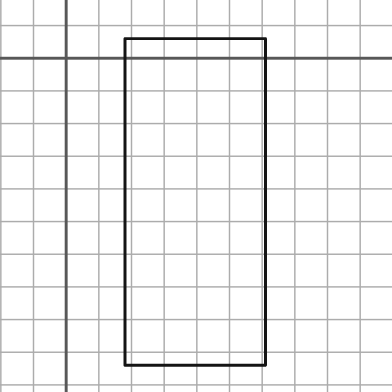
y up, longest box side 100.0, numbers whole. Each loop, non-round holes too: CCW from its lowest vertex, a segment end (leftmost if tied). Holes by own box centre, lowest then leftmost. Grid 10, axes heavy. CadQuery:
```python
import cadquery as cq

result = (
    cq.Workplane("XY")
    .moveTo(18.0, -94.0)
    .lineTo(61.0, -94.0)
    .lineTo(61.0, 6.0)
    .lineTo(18.0, 6.0)
    .close()
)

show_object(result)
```